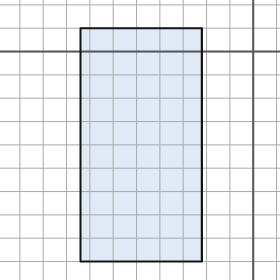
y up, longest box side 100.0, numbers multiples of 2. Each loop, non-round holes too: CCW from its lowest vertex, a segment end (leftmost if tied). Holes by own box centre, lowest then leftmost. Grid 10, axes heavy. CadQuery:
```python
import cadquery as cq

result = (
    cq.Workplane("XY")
    .moveTo(-74.0, -90.0)
    .lineTo(-22.0, -90.0)
    .lineTo(-22.0, 10.0)
    .lineTo(-74.0, 10.0)
    .close()
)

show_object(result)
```